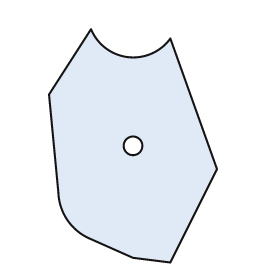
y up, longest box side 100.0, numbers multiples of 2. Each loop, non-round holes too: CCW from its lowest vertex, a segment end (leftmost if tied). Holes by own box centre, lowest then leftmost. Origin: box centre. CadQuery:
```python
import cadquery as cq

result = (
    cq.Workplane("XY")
    .moveTo(16.0, -50.0)
    .lineTo(36.0, -10.0)
    .lineTo(16.0, 46.0)
    .threePointArc((-2.0, 38.0), (-18.0, 50.0))
    .lineTo(-36.0, 22.0)
    .lineTo(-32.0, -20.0)
    .threePointArc((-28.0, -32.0), (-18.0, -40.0))
    .lineTo(0.0, -48.0)
    .close()
    .moveTo(0.0, 0.0)
    .circle(4.0)
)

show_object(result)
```